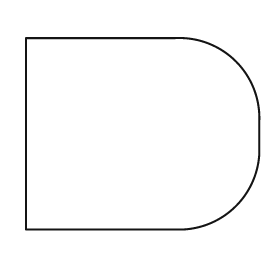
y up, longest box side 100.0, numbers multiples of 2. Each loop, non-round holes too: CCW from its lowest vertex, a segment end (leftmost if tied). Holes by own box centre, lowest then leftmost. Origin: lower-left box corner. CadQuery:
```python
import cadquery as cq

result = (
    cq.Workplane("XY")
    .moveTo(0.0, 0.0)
    .lineTo(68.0, 0.0)
    .threePointArc((90.0, 10.0), (100.0, 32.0))
    .lineTo(100.0, 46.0)
    .threePointArc((90.0, 72.0), (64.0, 82.0))
    .lineTo(0.0, 82.0)
    .close()
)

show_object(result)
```